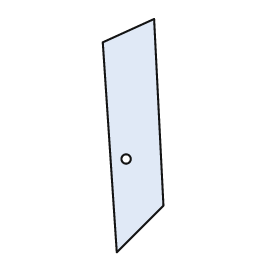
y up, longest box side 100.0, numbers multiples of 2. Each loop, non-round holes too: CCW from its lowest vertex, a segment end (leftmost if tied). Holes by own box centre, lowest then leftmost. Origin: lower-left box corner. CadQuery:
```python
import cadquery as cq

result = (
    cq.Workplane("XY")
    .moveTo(6.0, 0.0)
    .lineTo(26.0, 20.0)
    .lineTo(22.0, 100.0)
    .lineTo(0.0, 90.0)
    .close()
    .moveTo(10.0, 40.0)
    .circle(2.0)
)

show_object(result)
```